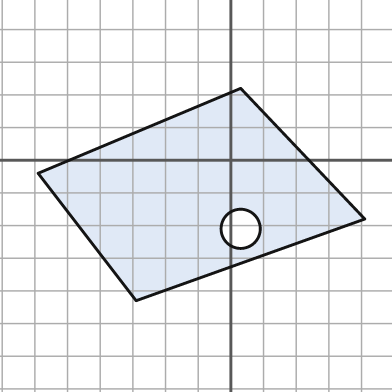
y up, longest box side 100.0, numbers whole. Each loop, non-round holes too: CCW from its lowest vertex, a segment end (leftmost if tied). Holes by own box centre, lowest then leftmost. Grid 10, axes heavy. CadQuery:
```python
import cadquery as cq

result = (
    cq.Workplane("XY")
    .moveTo(-29.0, -43.0)
    .lineTo(41.0, -18.0)
    .lineTo(3.0, 22.0)
    .lineTo(-59.0, -4.0)
    .close()
    .moveTo(3.0, -21.0)
    .circle(6.0)
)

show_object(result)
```